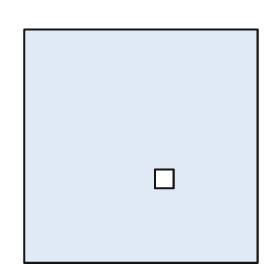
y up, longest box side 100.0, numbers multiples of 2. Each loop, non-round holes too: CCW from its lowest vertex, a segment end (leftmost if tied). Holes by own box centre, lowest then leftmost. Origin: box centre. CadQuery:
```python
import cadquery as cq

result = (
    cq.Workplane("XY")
    .moveTo(-50.0, -50.0)
    .lineTo(50.0, -50.0)
    .lineTo(50.0, 50.0)
    .lineTo(-50.0, 50.0)
    .close()
    .moveTo(6.0, -18.0)
    .lineTo(14.0, -18.0)
    .lineTo(14.0, -10.0)
    .lineTo(6.0, -10.0)
    .close()
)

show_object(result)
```